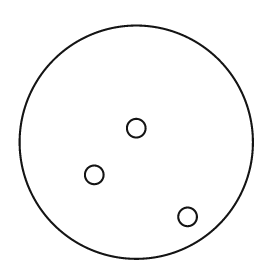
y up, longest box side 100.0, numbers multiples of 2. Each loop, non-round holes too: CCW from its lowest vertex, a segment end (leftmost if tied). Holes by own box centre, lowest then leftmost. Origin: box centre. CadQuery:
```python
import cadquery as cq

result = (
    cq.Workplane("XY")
    .moveTo(0.0, 0.0)
    .circle(50.0)
    .moveTo(22.0, -32.0)
    .circle(4.0)
    .moveTo(-18.0, -14.0)
    .circle(4.0)
    .moveTo(0.0, 6.0)
    .circle(4.0)
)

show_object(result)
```